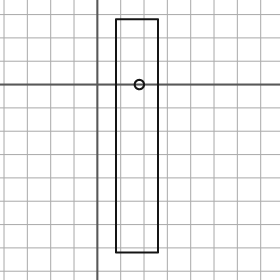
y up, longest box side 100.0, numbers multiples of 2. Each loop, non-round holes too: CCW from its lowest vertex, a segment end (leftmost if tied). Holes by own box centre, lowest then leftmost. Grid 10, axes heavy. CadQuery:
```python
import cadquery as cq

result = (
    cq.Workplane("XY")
    .moveTo(8.0, -72.0)
    .lineTo(26.0, -72.0)
    .lineTo(26.0, 28.0)
    .lineTo(8.0, 28.0)
    .close()
    .moveTo(18.0, 0.0)
    .circle(2.0)
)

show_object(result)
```